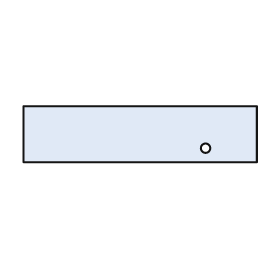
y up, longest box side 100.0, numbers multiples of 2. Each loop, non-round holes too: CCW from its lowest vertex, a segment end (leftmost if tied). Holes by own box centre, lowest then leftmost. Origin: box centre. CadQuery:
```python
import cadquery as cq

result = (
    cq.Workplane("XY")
    .moveTo(-50.0, -12.0)
    .lineTo(50.0, -12.0)
    .lineTo(50.0, 12.0)
    .lineTo(-50.0, 12.0)
    .close()
    .moveTo(28.0, -6.0)
    .circle(2.0)
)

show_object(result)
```